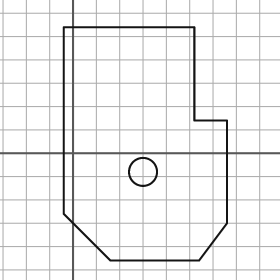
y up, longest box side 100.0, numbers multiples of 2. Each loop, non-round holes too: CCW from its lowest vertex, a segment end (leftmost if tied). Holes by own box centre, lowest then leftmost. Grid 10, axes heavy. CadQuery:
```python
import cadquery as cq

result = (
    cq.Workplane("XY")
    .moveTo(16.0, -46.0)
    .lineTo(54.0, -46.0)
    .lineTo(66.0, -30.0)
    .lineTo(66.0, 14.0)
    .lineTo(52.0, 14.0)
    .lineTo(52.0, 54.0)
    .lineTo(-4.0, 54.0)
    .lineTo(-4.0, -26.0)
    .close()
    .moveTo(30.0, -8.0)
    .circle(6.0)
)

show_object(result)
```